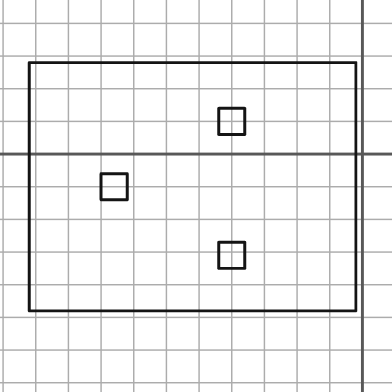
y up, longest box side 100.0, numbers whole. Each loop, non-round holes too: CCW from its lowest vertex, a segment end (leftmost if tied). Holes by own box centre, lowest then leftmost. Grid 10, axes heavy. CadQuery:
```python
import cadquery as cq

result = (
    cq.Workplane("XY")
    .moveTo(-102.0, -48.0)
    .lineTo(-2.0, -48.0)
    .lineTo(-2.0, 28.0)
    .lineTo(-102.0, 28.0)
    .close()
    .moveTo(-44.0, -35.0)
    .lineTo(-36.0, -35.0)
    .lineTo(-36.0, -27.0)
    .lineTo(-44.0, -27.0)
    .close()
    .moveTo(-80.0, -14.0)
    .lineTo(-72.0, -14.0)
    .lineTo(-72.0, -6.0)
    .lineTo(-80.0, -6.0)
    .close()
    .moveTo(-44.0, 6.0)
    .lineTo(-36.0, 6.0)
    .lineTo(-36.0, 14.0)
    .lineTo(-44.0, 14.0)
    .close()
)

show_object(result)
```